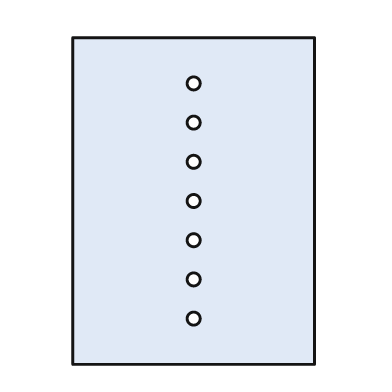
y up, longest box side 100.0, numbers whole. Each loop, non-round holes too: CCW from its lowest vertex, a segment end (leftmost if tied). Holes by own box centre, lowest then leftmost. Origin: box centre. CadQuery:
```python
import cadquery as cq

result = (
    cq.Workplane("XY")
    .moveTo(-37.0, -50.0)
    .lineTo(37.0, -50.0)
    .lineTo(37.0, 50.0)
    .lineTo(-37.0, 50.0)
    .close()
    .moveTo(0.0, -36.0)
    .circle(2.0)
    .moveTo(0.0, -24.0)
    .circle(2.0)
    .moveTo(0.0, -12.0)
    .circle(2.0)
    .moveTo(0.0, 0.0)
    .circle(2.0)
    .moveTo(0.0, 12.0)
    .circle(2.0)
    .moveTo(0.0, 24.0)
    .circle(2.0)
    .moveTo(0.0, 36.0)
    .circle(2.0)
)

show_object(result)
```